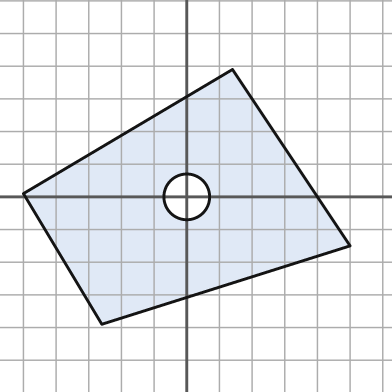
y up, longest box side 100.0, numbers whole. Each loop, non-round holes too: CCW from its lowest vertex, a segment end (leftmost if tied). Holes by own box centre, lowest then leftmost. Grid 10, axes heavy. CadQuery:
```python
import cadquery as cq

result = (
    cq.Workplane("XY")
    .moveTo(-26.0, -39.0)
    .lineTo(50.0, -15.0)
    .lineTo(14.0, 39.0)
    .lineTo(-50.0, 1.0)
    .close()
    .moveTo(0.0, 0.0)
    .circle(7.0)
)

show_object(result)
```